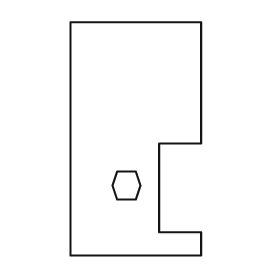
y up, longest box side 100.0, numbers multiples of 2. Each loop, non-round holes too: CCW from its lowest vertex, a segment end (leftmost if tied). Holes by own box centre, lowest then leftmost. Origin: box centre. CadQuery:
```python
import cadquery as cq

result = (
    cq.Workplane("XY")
    .moveTo(-28.0, -50.0)
    .lineTo(28.0, -50.0)
    .lineTo(28.0, -40.0)
    .lineTo(10.0, -40.0)
    .lineTo(10.0, -2.0)
    .lineTo(28.0, -2.0)
    .lineTo(28.0, 50.0)
    .lineTo(-28.0, 50.0)
    .close()
    .moveTo(-8.0, -26.0)
    .lineTo(0.0, -26.0)
    .lineTo(2.0, -20.0)
    .lineTo(0.0, -14.0)
    .lineTo(-8.0, -14.0)
    .lineTo(-10.0, -20.0)
    .close()
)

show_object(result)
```